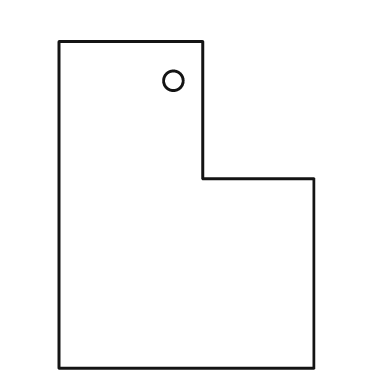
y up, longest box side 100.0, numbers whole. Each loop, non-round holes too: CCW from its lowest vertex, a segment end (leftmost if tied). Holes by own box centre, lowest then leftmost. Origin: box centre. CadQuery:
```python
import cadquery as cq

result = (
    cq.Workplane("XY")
    .moveTo(-39.0, -50.0)
    .lineTo(39.0, -50.0)
    .lineTo(39.0, 8.0)
    .lineTo(5.0, 8.0)
    .lineTo(5.0, 50.0)
    .lineTo(-39.0, 50.0)
    .close()
    .moveTo(-4.0, 38.0)
    .circle(3.0)
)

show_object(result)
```